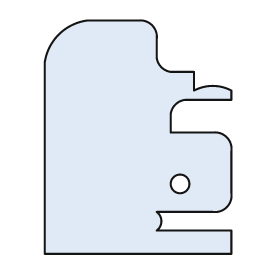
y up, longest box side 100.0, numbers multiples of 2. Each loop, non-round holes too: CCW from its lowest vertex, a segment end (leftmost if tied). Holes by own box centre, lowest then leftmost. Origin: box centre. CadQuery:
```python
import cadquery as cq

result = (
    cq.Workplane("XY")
    .moveTo(-40.0, -50.0)
    .lineTo(40.0, -50.0)
    .lineTo(40.0, -40.0)
    .lineTo(8.0, -40.0)
    .threePointArc((10.0, -36.0), (8.0, -32.0))
    .lineTo(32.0, -32.0)
    .threePointArc((38.0, -30.0), (40.0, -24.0))
    .lineTo(40.0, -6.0)
    .threePointArc((38.0, 0.0), (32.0, 2.0))
    .lineTo(14.0, 2.0)
    .lineTo(14.0, 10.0)
    .threePointArc((16.0, 14.0), (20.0, 16.0))
    .lineTo(40.0, 16.0)
    .lineTo(40.0, 20.0)
    .threePointArc((32.0, 22.0), (24.0, 20.0))
    .lineTo(24.0, 28.0)
    .lineTo(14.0, 28.0)
    .threePointArc((10.0, 30.0), (8.0, 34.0))
    .lineTo(8.0, 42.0)
    .threePointArc((6.0, 48.0), (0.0, 50.0))
    .lineTo(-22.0, 50.0)
    .threePointArc((-34.0, 44.0), (-40.0, 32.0))
    .close()
    .moveTo(18.0, -20.0)
    .circle(4.0)
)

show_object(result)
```